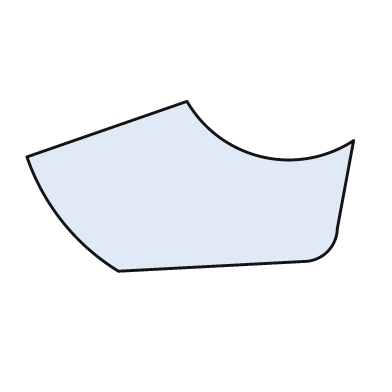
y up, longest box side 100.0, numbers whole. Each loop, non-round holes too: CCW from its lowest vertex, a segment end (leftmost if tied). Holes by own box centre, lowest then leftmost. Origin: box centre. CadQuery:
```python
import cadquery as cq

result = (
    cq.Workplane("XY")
    .moveTo(-22.0, -26.0)
    .lineTo(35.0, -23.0)
    .threePointArc((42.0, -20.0), (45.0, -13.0))
    .lineTo(50.0, 14.0)
    .threePointArc((22.0, 9.0), (-1.0, 26.0))
    .lineTo(-50.0, 9.0)
    .threePointArc((-39.0, -11.0), (-22.0, -26.0))
    .close()
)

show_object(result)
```